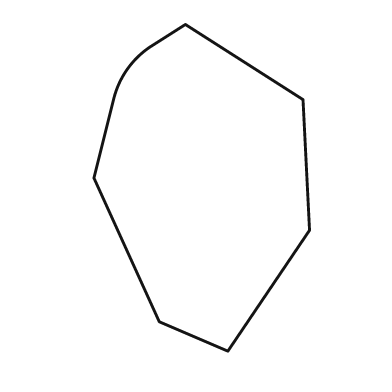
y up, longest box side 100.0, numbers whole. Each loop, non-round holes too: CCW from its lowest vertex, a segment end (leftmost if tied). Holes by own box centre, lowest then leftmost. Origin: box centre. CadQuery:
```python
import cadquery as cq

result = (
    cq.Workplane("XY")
    .moveTo(8.0, -50.0)
    .lineTo(33.0, -13.0)
    .lineTo(31.0, 27.0)
    .lineTo(-5.0, 50.0)
    .lineTo(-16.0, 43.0)
    .threePointArc((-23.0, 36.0), (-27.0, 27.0))
    .lineTo(-33.0, 3.0)
    .lineTo(-13.0, -41.0)
    .close()
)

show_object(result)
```